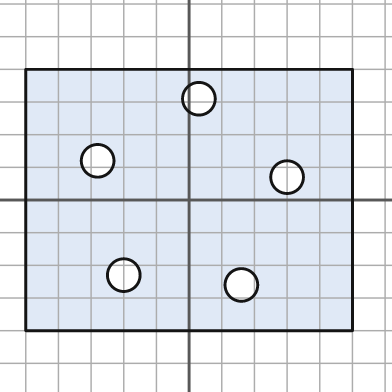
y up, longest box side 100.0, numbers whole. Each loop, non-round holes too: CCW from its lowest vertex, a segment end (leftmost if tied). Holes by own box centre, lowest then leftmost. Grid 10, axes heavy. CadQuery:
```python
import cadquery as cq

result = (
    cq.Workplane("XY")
    .moveTo(-50.0, -40.0)
    .lineTo(50.0, -40.0)
    .lineTo(50.0, 40.0)
    .lineTo(-50.0, 40.0)
    .close()
    .moveTo(16.0, -26.0)
    .circle(5.0)
    .moveTo(-20.0, -23.0)
    .circle(5.0)
    .moveTo(30.0, 7.0)
    .circle(5.0)
    .moveTo(-28.0, 12.0)
    .circle(5.0)
    .moveTo(3.0, 31.0)
    .circle(5.0)
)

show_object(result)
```